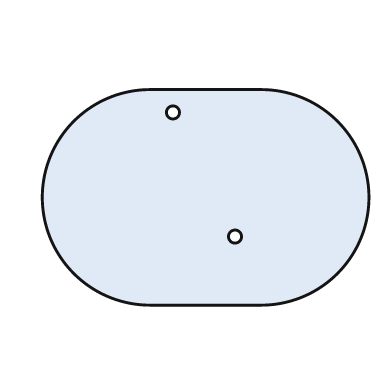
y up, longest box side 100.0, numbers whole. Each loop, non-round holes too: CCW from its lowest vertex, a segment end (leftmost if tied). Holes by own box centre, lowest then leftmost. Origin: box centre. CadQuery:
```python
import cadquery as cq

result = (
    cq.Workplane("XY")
    .moveTo(-17.0, -33.0)
    .lineTo(17.0, -33.0)
    .threePointArc((50.0, 0.0), (17.0, 33.0))
    .lineTo(-17.0, 33.0)
    .threePointArc((-50.0, 0.0), (-17.0, -33.0))
    .close()
    .moveTo(9.0, -12.0)
    .circle(2.0)
    .moveTo(-10.0, 26.0)
    .circle(2.0)
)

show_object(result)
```